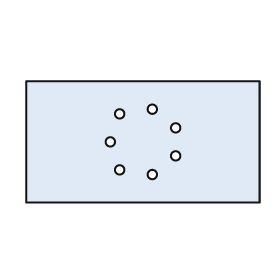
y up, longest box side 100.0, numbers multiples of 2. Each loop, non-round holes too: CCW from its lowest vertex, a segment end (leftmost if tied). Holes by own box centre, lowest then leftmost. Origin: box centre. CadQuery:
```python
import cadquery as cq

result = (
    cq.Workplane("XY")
    .moveTo(-50.0, -26.0)
    .lineTo(50.0, -26.0)
    .lineTo(50.0, 26.0)
    .lineTo(-50.0, 26.0)
    .close()
    .moveTo(4.0, -14.0)
    .circle(2.0)
    .moveTo(-10.0, -12.0)
    .circle(2.0)
    .moveTo(14.0, -6.0)
    .circle(2.0)
    .moveTo(-14.0, 0.0)
    .circle(2.0)
    .moveTo(14.0, 6.0)
    .circle(2.0)
    .moveTo(-10.0, 12.0)
    .circle(2.0)
    .moveTo(4.0, 14.0)
    .circle(2.0)
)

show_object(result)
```